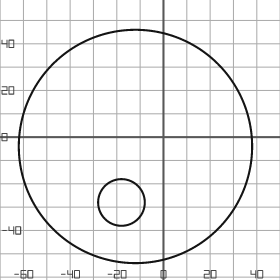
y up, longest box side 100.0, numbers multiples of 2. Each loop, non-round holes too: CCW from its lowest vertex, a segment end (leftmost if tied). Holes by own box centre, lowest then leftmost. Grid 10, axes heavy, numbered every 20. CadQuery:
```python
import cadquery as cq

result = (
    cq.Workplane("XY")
    .moveTo(-12.0, -4.0)
    .circle(50.0)
    .moveTo(-18.0, -28.0)
    .circle(10.0)
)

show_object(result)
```